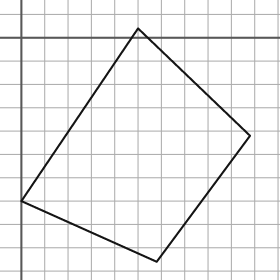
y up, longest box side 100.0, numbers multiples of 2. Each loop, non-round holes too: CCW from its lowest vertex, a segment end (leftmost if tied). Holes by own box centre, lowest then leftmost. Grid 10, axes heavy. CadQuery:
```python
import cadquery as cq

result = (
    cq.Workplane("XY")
    .moveTo(58.0, -96.0)
    .lineTo(98.0, -42.0)
    .lineTo(50.0, 4.0)
    .lineTo(0.0, -70.0)
    .close()
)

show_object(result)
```